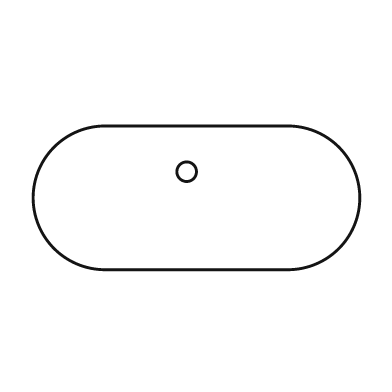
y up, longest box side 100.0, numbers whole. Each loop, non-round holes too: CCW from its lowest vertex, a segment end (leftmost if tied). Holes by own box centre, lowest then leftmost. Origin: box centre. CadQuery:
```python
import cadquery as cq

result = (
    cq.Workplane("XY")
    .moveTo(-28.0, -22.0)
    .lineTo(28.0, -22.0)
    .threePointArc((50.0, 0.0), (28.0, 22.0))
    .lineTo(-28.0, 22.0)
    .threePointArc((-50.0, 0.0), (-28.0, -22.0))
    .close()
    .moveTo(-3.0, 8.0)
    .circle(3.0)
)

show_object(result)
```